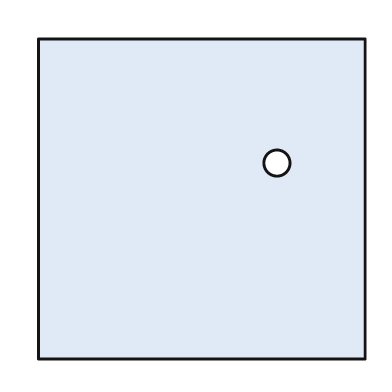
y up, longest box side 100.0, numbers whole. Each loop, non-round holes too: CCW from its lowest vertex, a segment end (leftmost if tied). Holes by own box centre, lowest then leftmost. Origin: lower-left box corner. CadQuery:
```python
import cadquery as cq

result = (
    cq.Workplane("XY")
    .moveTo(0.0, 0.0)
    .lineTo(100.0, 0.0)
    .lineTo(100.0, 98.0)
    .lineTo(0.0, 98.0)
    .close()
    .moveTo(73.0, 60.0)
    .circle(4.0)
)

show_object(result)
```